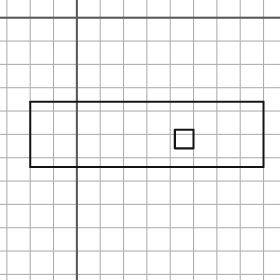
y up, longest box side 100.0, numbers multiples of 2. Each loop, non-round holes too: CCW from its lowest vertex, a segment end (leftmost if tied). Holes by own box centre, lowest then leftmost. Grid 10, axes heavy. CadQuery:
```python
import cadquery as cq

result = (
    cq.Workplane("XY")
    .moveTo(-20.0, -64.0)
    .lineTo(80.0, -64.0)
    .lineTo(80.0, -36.0)
    .lineTo(-20.0, -36.0)
    .close()
    .moveTo(42.0, -56.0)
    .lineTo(50.0, -56.0)
    .lineTo(50.0, -48.0)
    .lineTo(42.0, -48.0)
    .close()
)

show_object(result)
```